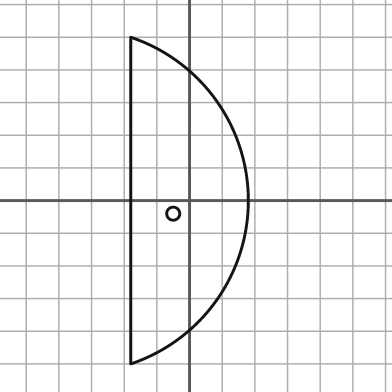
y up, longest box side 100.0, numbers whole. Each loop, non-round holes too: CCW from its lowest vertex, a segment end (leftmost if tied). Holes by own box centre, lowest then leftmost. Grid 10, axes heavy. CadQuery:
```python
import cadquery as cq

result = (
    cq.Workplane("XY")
    .moveTo(-18.0, -50.0)
    .threePointArc((18.0, 0.0), (-18.0, 50.0))
    .close()
    .moveTo(-5.0, -4.0)
    .circle(2.0)
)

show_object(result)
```